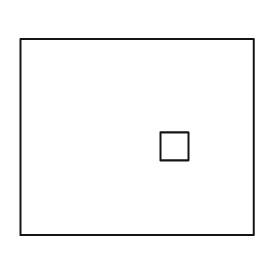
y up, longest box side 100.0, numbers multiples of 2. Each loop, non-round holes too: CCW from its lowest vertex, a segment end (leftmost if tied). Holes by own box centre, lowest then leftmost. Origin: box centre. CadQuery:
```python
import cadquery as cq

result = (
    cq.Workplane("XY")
    .moveTo(-50.0, -42.0)
    .lineTo(50.0, -42.0)
    .lineTo(50.0, 42.0)
    .lineTo(-50.0, 42.0)
    .close()
    .moveTo(10.0, -10.0)
    .lineTo(22.0, -10.0)
    .lineTo(22.0, 2.0)
    .lineTo(10.0, 2.0)
    .close()
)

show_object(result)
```